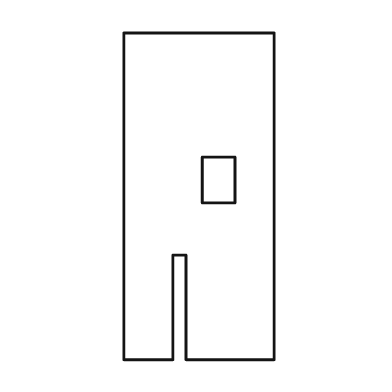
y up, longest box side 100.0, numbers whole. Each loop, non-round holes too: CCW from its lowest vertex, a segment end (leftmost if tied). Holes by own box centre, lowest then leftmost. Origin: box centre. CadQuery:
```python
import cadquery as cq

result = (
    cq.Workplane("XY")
    .moveTo(-23.0, -50.0)
    .lineTo(-8.0, -50.0)
    .lineTo(-8.0, -18.0)
    .lineTo(-4.0, -18.0)
    .lineTo(-4.0, -50.0)
    .lineTo(23.0, -50.0)
    .lineTo(23.0, 50.0)
    .lineTo(-23.0, 50.0)
    .close()
    .moveTo(1.0, -2.0)
    .lineTo(11.0, -2.0)
    .lineTo(11.0, 12.0)
    .lineTo(1.0, 12.0)
    .close()
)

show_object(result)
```